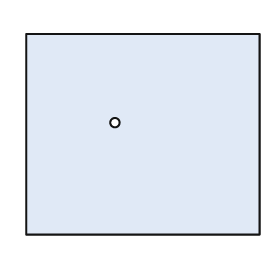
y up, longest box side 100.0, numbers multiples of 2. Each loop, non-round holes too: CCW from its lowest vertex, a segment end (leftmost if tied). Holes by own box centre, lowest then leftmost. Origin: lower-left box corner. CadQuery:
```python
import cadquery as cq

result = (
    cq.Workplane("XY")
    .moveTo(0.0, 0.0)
    .lineTo(100.0, 0.0)
    .lineTo(100.0, 86.0)
    .lineTo(0.0, 86.0)
    .close()
    .moveTo(38.0, 48.0)
    .circle(2.0)
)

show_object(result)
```